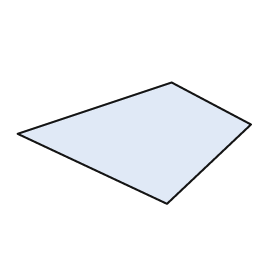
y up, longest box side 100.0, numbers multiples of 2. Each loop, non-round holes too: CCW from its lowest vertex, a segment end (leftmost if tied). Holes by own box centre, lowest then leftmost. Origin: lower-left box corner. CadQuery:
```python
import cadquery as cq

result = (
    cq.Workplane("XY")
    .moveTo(64.0, 0.0)
    .lineTo(100.0, 34.0)
    .lineTo(66.0, 52.0)
    .lineTo(0.0, 30.0)
    .close()
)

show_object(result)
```